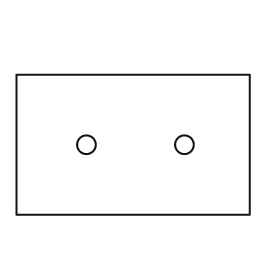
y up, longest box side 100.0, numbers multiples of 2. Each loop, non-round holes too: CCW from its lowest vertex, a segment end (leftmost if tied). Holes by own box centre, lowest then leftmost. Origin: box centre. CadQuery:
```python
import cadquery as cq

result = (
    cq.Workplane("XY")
    .moveTo(-50.0, -30.0)
    .lineTo(50.0, -30.0)
    .lineTo(50.0, 30.0)
    .lineTo(-50.0, 30.0)
    .close()
    .moveTo(-20.0, 0.0)
    .circle(4.0)
    .moveTo(22.0, 0.0)
    .circle(4.0)
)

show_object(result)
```